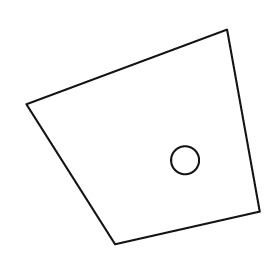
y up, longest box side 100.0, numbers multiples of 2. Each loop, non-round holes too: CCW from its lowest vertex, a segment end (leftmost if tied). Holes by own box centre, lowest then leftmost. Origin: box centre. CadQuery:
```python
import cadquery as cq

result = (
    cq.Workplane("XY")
    .moveTo(-12.0, -46.0)
    .lineTo(50.0, -32.0)
    .lineTo(36.0, 46.0)
    .lineTo(-50.0, 14.0)
    .close()
    .moveTo(18.0, -10.0)
    .circle(6.0)
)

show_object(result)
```